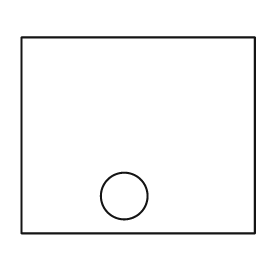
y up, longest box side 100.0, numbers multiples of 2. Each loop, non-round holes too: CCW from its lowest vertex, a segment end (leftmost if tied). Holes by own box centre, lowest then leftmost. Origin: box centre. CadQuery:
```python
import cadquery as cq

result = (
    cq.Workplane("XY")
    .moveTo(-50.0, -42.0)
    .lineTo(50.0, -42.0)
    .lineTo(50.0, 42.0)
    .lineTo(-50.0, 42.0)
    .close()
    .moveTo(-6.0, -26.0)
    .circle(10.0)
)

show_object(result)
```